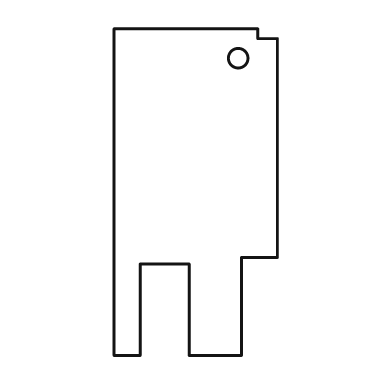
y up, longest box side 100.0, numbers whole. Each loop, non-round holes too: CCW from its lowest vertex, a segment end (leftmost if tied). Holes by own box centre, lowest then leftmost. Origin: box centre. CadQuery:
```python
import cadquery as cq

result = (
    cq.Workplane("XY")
    .moveTo(-25.0, -50.0)
    .lineTo(-17.0, -50.0)
    .lineTo(-17.0, -22.0)
    .lineTo(-2.0, -22.0)
    .lineTo(-2.0, -50.0)
    .lineTo(14.0, -50.0)
    .lineTo(14.0, -20.0)
    .lineTo(25.0, -20.0)
    .lineTo(25.0, 47.0)
    .lineTo(19.0, 47.0)
    .lineTo(19.0, 50.0)
    .lineTo(-25.0, 50.0)
    .close()
    .moveTo(13.0, 41.0)
    .circle(3.0)
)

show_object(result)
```